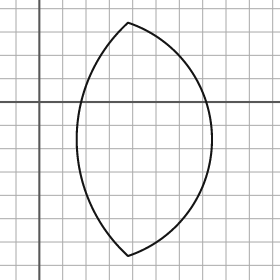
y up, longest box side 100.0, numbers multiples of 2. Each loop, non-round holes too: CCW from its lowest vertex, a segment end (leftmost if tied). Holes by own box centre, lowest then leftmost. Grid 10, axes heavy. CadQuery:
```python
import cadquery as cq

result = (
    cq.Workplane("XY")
    .moveTo(38.0, -66.0)
    .threePointArc((74.0, -16.0), (38.0, 34.0))
    .threePointArc((16.0, -16.0), (38.0, -66.0))
    .close()
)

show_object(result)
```